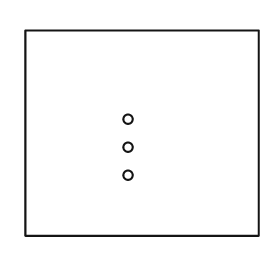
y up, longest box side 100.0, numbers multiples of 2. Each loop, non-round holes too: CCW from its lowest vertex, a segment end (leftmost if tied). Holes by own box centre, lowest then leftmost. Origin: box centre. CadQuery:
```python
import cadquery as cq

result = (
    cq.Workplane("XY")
    .moveTo(-50.0, -44.0)
    .lineTo(50.0, -44.0)
    .lineTo(50.0, 44.0)
    .lineTo(-50.0, 44.0)
    .close()
    .moveTo(-6.0, -18.0)
    .circle(2.0)
    .moveTo(-6.0, -6.0)
    .circle(2.0)
    .moveTo(-6.0, 6.0)
    .circle(2.0)
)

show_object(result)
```